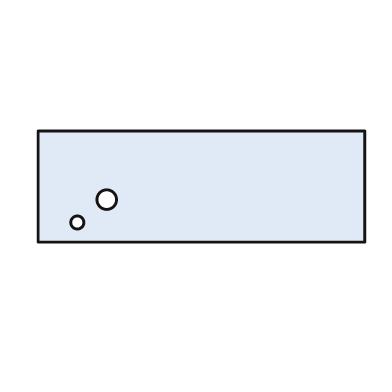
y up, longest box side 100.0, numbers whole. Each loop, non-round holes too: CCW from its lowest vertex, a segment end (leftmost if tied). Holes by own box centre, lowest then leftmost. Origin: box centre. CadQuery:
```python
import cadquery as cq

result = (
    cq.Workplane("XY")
    .moveTo(-50.0, -17.0)
    .lineTo(50.0, -17.0)
    .lineTo(50.0, 17.0)
    .lineTo(-50.0, 17.0)
    .close()
    .moveTo(-38.0, -11.0)
    .circle(2.0)
    .moveTo(-29.0, -4.0)
    .circle(3.0)
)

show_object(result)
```